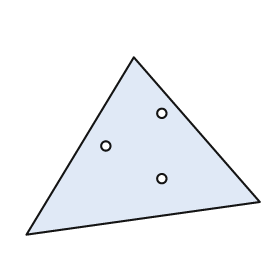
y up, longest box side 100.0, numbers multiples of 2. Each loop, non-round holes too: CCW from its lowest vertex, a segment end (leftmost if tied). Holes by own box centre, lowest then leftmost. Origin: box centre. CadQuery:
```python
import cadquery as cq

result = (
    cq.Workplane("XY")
    .moveTo(-50.0, -38.0)
    .lineTo(50.0, -24.0)
    .lineTo(-4.0, 38.0)
    .close()
    .moveTo(8.0, -14.0)
    .circle(2.0)
    .moveTo(-16.0, 0.0)
    .circle(2.0)
    .moveTo(8.0, 14.0)
    .circle(2.0)
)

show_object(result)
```